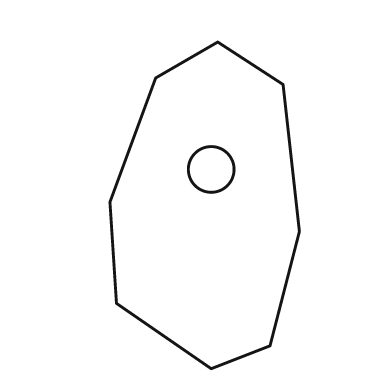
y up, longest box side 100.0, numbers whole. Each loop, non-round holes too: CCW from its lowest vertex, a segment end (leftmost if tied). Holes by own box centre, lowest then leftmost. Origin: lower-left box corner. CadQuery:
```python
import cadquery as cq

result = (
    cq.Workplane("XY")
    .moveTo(31.0, 0.0)
    .lineTo(49.0, 7.0)
    .lineTo(58.0, 42.0)
    .lineTo(53.0, 87.0)
    .lineTo(33.0, 100.0)
    .lineTo(14.0, 89.0)
    .lineTo(0.0, 51.0)
    .lineTo(2.0, 20.0)
    .close()
    .moveTo(31.0, 61.0)
    .circle(7.0)
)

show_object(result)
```